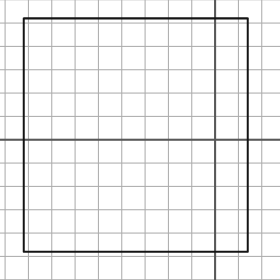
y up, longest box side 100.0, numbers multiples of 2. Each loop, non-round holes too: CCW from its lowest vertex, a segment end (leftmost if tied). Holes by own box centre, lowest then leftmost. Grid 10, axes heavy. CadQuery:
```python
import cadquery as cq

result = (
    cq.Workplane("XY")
    .moveTo(-82.0, -48.0)
    .lineTo(14.0, -48.0)
    .lineTo(14.0, 52.0)
    .lineTo(-82.0, 52.0)
    .close()
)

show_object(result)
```